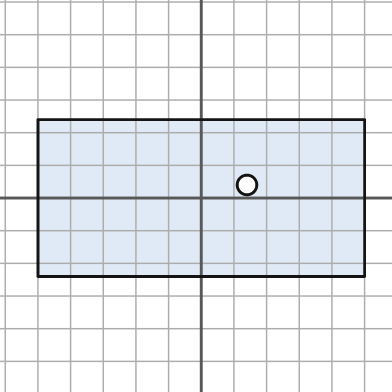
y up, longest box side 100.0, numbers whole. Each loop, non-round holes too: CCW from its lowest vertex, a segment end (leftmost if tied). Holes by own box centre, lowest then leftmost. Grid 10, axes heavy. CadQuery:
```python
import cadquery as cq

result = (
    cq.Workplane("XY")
    .moveTo(-50.0, -24.0)
    .lineTo(50.0, -24.0)
    .lineTo(50.0, 24.0)
    .lineTo(-50.0, 24.0)
    .close()
    .moveTo(14.0, 4.0)
    .circle(3.0)
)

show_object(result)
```